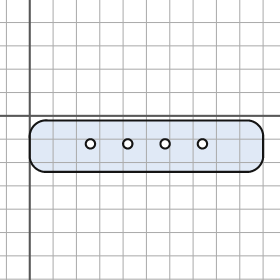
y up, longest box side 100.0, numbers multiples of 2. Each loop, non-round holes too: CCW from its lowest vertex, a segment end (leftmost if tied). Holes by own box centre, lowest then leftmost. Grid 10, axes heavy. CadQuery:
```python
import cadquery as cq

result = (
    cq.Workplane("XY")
    .moveTo(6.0, -24.0)
    .lineTo(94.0, -24.0)
    .threePointArc((98.0, -22.0), (100.0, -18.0))
    .lineTo(100.0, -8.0)
    .threePointArc((98.0, -4.0), (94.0, -2.0))
    .lineTo(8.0, -2.0)
    .threePointArc((2.0, -4.0), (0.0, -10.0))
    .lineTo(0.0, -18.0)
    .threePointArc((2.0, -22.0), (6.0, -24.0))
    .close()
    .moveTo(26.0, -12.0)
    .circle(2.0)
    .moveTo(42.0, -12.0)
    .circle(2.0)
    .moveTo(58.0, -12.0)
    .circle(2.0)
    .moveTo(74.0, -12.0)
    .circle(2.0)
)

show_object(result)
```